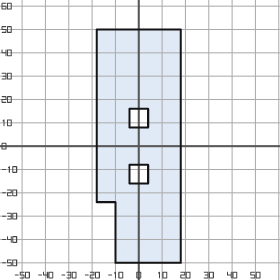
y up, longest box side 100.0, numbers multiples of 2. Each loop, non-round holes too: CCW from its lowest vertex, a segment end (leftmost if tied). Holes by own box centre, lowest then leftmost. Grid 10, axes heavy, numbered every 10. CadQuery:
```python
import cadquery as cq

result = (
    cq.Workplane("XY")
    .moveTo(-10.0, -50.0)
    .lineTo(18.0, -50.0)
    .lineTo(18.0, 50.0)
    .lineTo(-18.0, 50.0)
    .lineTo(-18.0, -24.0)
    .lineTo(-10.0, -24.0)
    .close()
    .moveTo(-4.0, -16.0)
    .lineTo(4.0, -16.0)
    .lineTo(4.0, -8.0)
    .lineTo(-4.0, -8.0)
    .close()
    .moveTo(-4.0, 8.0)
    .lineTo(4.0, 8.0)
    .lineTo(4.0, 16.0)
    .lineTo(-4.0, 16.0)
    .close()
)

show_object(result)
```